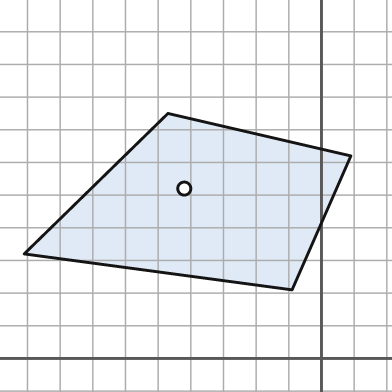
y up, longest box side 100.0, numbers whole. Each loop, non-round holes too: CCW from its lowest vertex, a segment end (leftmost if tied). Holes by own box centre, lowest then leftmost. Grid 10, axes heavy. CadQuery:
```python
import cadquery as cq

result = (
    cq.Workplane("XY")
    .moveTo(-9.0, 21.0)
    .lineTo(9.0, 62.0)
    .lineTo(-47.0, 75.0)
    .lineTo(-91.0, 32.0)
    .close()
    .moveTo(-42.0, 52.0)
    .circle(2.0)
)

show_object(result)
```